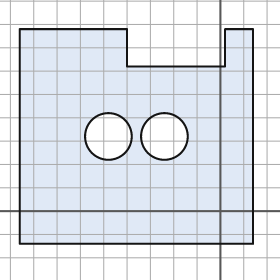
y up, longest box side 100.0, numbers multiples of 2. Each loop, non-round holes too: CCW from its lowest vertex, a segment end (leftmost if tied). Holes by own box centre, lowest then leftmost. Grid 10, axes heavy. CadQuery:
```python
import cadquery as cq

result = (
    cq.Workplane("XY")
    .moveTo(-86.0, -14.0)
    .lineTo(14.0, -14.0)
    .lineTo(14.0, 78.0)
    .lineTo(2.0, 78.0)
    .lineTo(2.0, 62.0)
    .lineTo(-40.0, 62.0)
    .lineTo(-40.0, 78.0)
    .lineTo(-86.0, 78.0)
    .close()
    .moveTo(-48.0, 32.0)
    .circle(10.0)
    .moveTo(-24.0, 32.0)
    .circle(10.0)
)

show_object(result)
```